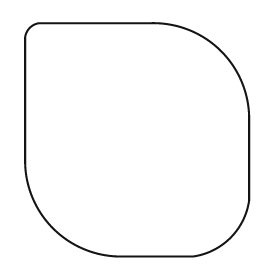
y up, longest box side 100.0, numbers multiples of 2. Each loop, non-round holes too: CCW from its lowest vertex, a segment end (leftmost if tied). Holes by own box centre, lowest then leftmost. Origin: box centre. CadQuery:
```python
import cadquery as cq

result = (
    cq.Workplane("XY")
    .moveTo(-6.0, -50.0)
    .lineTo(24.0, -50.0)
    .threePointArc((40.0, -42.0), (48.0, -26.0))
    .lineTo(48.0, 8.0)
    .threePointArc((36.0, 38.0), (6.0, 50.0))
    .lineTo(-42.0, 50.0)
    .threePointArc((-46.0, 48.0), (-48.0, 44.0))
    .lineTo(-48.0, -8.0)
    .threePointArc((-36.0, -38.0), (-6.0, -50.0))
    .close()
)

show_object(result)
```